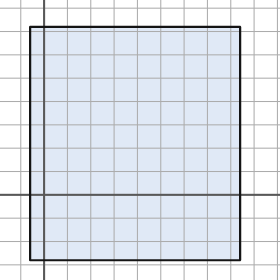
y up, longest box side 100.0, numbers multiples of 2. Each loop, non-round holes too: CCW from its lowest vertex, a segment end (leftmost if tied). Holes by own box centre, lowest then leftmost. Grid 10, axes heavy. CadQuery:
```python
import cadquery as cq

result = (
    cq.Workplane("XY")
    .moveTo(-6.0, -28.0)
    .lineTo(84.0, -28.0)
    .lineTo(84.0, 72.0)
    .lineTo(-6.0, 72.0)
    .close()
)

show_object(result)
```